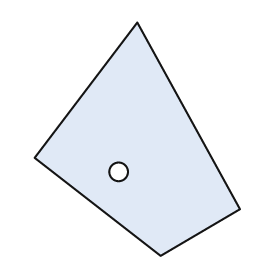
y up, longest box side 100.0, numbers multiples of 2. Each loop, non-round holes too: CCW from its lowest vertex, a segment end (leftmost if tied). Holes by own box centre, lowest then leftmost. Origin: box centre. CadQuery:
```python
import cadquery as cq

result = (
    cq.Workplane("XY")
    .moveTo(10.0, -50.0)
    .lineTo(44.0, -30.0)
    .lineTo(0.0, 50.0)
    .lineTo(-44.0, -8.0)
    .close()
    .moveTo(-8.0, -14.0)
    .circle(4.0)
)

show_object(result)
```